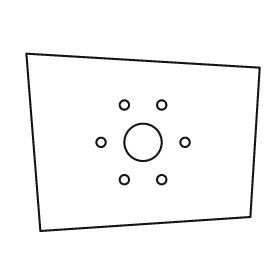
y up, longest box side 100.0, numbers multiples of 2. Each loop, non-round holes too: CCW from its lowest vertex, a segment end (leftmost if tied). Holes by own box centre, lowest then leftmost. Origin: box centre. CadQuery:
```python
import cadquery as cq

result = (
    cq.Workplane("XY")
    .moveTo(-44.0, -38.0)
    .lineTo(46.0, -32.0)
    .lineTo(50.0, 32.0)
    .lineTo(-50.0, 38.0)
    .close()
    .moveTo(-8.0, -16.0)
    .circle(2.0)
    .moveTo(8.0, -16.0)
    .circle(2.0)
    .moveTo(-18.0, 0.0)
    .circle(2.0)
    .moveTo(0.0, 0.0)
    .circle(8.0)
    .moveTo(18.0, 0.0)
    .circle(2.0)
    .moveTo(-8.0, 16.0)
    .circle(2.0)
    .moveTo(8.0, 16.0)
    .circle(2.0)
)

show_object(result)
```